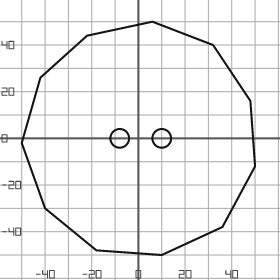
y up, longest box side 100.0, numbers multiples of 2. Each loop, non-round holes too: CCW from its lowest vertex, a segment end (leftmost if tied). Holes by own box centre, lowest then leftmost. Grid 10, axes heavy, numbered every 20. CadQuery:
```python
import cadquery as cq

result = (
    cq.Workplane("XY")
    .moveTo(10.0, -50.0)
    .lineTo(36.0, -38.0)
    .lineTo(50.0, -12.0)
    .lineTo(48.0, 16.0)
    .lineTo(32.0, 40.0)
    .lineTo(6.0, 50.0)
    .lineTo(-22.0, 44.0)
    .lineTo(-42.0, 26.0)
    .lineTo(-50.0, -2.0)
    .lineTo(-40.0, -30.0)
    .lineTo(-18.0, -48.0)
    .close()
    .moveTo(-8.0, 0.0)
    .circle(4.0)
    .moveTo(10.0, 0.0)
    .circle(4.0)
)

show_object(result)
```